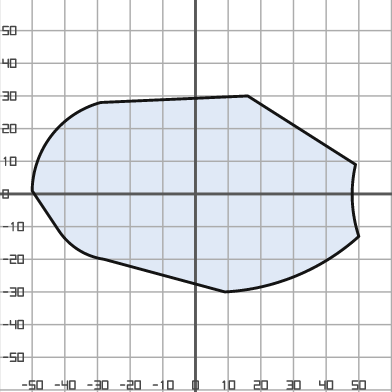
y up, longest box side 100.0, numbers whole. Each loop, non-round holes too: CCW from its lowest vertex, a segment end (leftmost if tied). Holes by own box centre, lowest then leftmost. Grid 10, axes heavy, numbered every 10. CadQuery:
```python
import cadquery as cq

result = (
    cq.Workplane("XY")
    .moveTo(9.0, -30.0)
    .threePointArc((31.0, -25.0), (50.0, -13.0))
    .threePointArc((48.0, -2.0), (49.0, 9.0))
    .lineTo(16.0, 30.0)
    .lineTo(-29.0, 28.0)
    .threePointArc((-44.0, 18.0), (-50.0, 1.0))
    .lineTo(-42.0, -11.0)
    .threePointArc((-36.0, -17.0), (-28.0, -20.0))
    .close()
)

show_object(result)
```